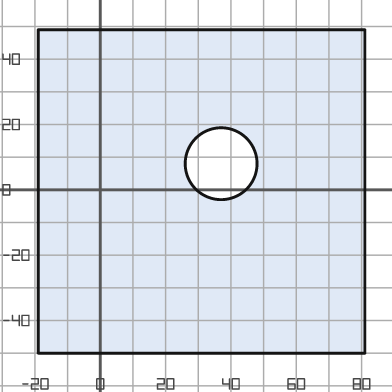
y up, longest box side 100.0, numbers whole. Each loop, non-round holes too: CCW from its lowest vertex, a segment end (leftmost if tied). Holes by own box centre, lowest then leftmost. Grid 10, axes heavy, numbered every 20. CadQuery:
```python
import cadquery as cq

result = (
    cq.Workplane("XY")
    .moveTo(-19.0, -50.0)
    .lineTo(81.0, -50.0)
    .lineTo(81.0, 49.0)
    .lineTo(-19.0, 49.0)
    .close()
    .moveTo(37.0, 8.0)
    .circle(11.0)
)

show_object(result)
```